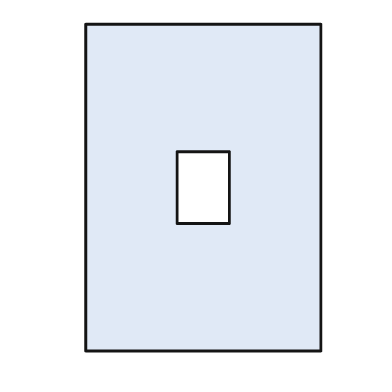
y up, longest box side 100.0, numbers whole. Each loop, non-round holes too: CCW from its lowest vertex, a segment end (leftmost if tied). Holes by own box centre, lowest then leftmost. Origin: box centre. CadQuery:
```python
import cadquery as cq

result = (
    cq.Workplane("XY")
    .moveTo(-36.0, -50.0)
    .lineTo(36.0, -50.0)
    .lineTo(36.0, 50.0)
    .lineTo(-36.0, 50.0)
    .close()
    .moveTo(-8.0, -11.0)
    .lineTo(8.0, -11.0)
    .lineTo(8.0, 11.0)
    .lineTo(-8.0, 11.0)
    .close()
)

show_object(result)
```